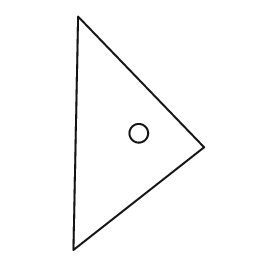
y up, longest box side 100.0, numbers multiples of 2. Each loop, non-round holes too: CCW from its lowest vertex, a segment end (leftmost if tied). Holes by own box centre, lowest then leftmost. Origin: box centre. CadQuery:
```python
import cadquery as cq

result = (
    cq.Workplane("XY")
    .moveTo(-28.0, -50.0)
    .lineTo(28.0, -6.0)
    .lineTo(-26.0, 50.0)
    .close()
    .moveTo(0.0, 0.0)
    .circle(4.0)
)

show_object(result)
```